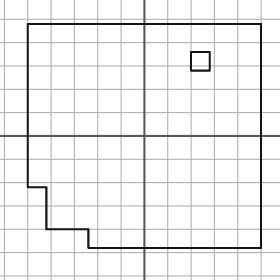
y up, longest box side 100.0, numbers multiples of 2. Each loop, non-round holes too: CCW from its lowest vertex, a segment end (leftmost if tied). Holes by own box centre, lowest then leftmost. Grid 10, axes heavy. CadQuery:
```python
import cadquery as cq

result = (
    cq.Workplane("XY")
    .moveTo(-24.0, -48.0)
    .lineTo(50.0, -48.0)
    .lineTo(50.0, 48.0)
    .lineTo(-50.0, 48.0)
    .lineTo(-50.0, -22.0)
    .lineTo(-42.0, -22.0)
    .lineTo(-42.0, -40.0)
    .lineTo(-24.0, -40.0)
    .close()
    .moveTo(20.0, 28.0)
    .lineTo(28.0, 28.0)
    .lineTo(28.0, 36.0)
    .lineTo(20.0, 36.0)
    .close()
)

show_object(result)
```